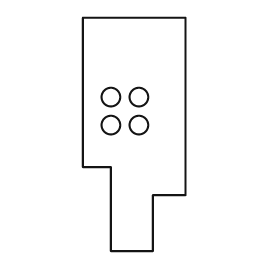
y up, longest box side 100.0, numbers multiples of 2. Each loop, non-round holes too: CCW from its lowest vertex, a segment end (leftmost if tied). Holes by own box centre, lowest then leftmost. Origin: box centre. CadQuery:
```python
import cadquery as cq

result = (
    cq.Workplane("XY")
    .moveTo(-10.0, -50.0)
    .lineTo(8.0, -50.0)
    .lineTo(8.0, -26.0)
    .lineTo(22.0, -26.0)
    .lineTo(22.0, 50.0)
    .lineTo(-22.0, 50.0)
    .lineTo(-22.0, -14.0)
    .lineTo(-10.0, -14.0)
    .close()
    .moveTo(-10.0, 4.0)
    .circle(4.0)
    .moveTo(2.0, 4.0)
    .circle(4.0)
    .moveTo(-10.0, 16.0)
    .circle(4.0)
    .moveTo(2.0, 16.0)
    .circle(4.0)
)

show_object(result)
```